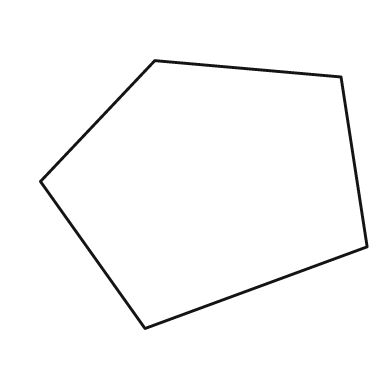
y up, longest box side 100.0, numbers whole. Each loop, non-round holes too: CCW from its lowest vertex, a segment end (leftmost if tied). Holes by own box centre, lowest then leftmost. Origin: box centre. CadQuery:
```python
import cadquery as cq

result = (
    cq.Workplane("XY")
    .moveTo(-18.0, -41.0)
    .lineTo(50.0, -16.0)
    .lineTo(42.0, 36.0)
    .lineTo(-15.0, 41.0)
    .lineTo(-50.0, 4.0)
    .close()
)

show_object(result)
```